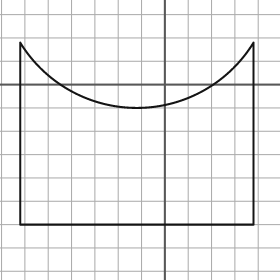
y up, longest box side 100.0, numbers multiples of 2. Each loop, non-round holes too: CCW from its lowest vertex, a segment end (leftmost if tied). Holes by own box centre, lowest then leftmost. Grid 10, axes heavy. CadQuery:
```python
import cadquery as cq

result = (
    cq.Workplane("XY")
    .moveTo(-62.0, -60.0)
    .lineTo(38.0, -60.0)
    .lineTo(38.0, 18.0)
    .threePointArc((-12.0, -10.0), (-62.0, 18.0))
    .close()
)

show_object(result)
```